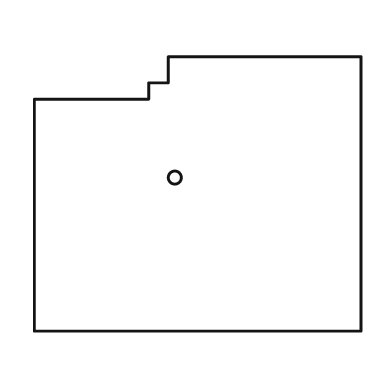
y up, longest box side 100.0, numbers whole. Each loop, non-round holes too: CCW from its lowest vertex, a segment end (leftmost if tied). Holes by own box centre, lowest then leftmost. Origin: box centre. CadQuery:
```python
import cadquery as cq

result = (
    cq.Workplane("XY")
    .moveTo(-50.0, -42.0)
    .lineTo(50.0, -42.0)
    .lineTo(50.0, 42.0)
    .lineTo(-9.0, 42.0)
    .lineTo(-9.0, 34.0)
    .lineTo(-15.0, 34.0)
    .lineTo(-15.0, 29.0)
    .lineTo(-50.0, 29.0)
    .close()
    .moveTo(-7.0, 5.0)
    .circle(2.0)
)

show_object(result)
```